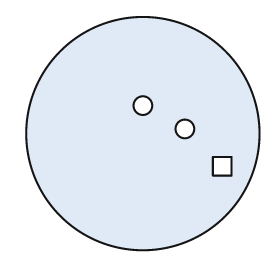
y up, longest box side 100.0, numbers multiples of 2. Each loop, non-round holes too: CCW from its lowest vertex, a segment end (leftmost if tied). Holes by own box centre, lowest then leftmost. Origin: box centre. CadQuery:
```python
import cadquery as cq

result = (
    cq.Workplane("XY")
    .moveTo(0.0, 0.0)
    .circle(50.0)
    .moveTo(30.0, -18.0)
    .lineTo(38.0, -18.0)
    .lineTo(38.0, -10.0)
    .lineTo(30.0, -10.0)
    .close()
    .moveTo(18.0, 2.0)
    .circle(4.0)
    .moveTo(0.0, 12.0)
    .circle(4.0)
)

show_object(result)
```